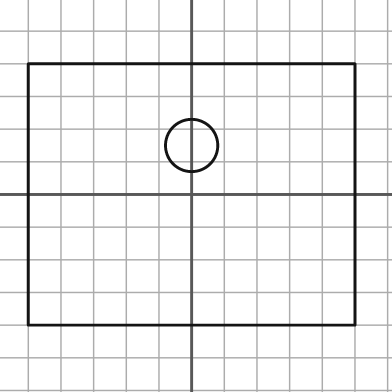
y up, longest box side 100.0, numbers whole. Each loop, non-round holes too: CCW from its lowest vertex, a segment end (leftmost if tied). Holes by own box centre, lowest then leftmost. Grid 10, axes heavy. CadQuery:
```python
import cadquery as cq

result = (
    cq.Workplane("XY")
    .moveTo(-50.0, -40.0)
    .lineTo(50.0, -40.0)
    .lineTo(50.0, 40.0)
    .lineTo(-50.0, 40.0)
    .close()
    .moveTo(0.0, 15.0)
    .circle(8.0)
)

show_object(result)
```